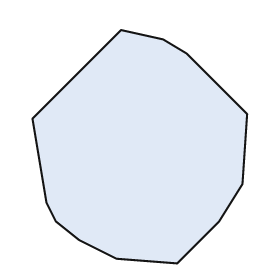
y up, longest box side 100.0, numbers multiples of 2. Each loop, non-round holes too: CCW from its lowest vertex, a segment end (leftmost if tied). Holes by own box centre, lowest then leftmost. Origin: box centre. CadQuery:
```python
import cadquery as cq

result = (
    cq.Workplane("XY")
    .moveTo(16.0, -50.0)
    .lineTo(34.0, -32.0)
    .lineTo(44.0, -16.0)
    .lineTo(46.0, 14.0)
    .lineTo(20.0, 40.0)
    .lineTo(10.0, 46.0)
    .lineTo(-8.0, 50.0)
    .lineTo(-46.0, 12.0)
    .lineTo(-40.0, -24.0)
    .lineTo(-36.0, -32.0)
    .lineTo(-26.0, -40.0)
    .lineTo(-10.0, -48.0)
    .close()
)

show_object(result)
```